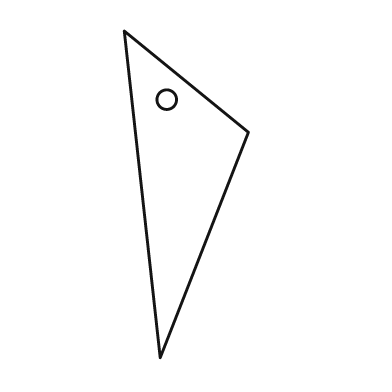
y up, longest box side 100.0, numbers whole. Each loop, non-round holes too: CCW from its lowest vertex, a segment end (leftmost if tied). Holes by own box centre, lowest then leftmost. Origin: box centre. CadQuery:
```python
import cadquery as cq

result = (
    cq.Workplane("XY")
    .moveTo(-8.0, -50.0)
    .lineTo(19.0, 19.0)
    .lineTo(-19.0, 50.0)
    .close()
    .moveTo(-6.0, 29.0)
    .circle(3.0)
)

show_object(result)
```